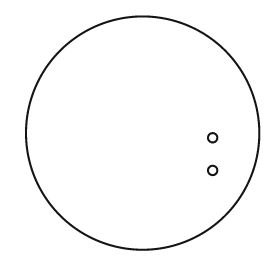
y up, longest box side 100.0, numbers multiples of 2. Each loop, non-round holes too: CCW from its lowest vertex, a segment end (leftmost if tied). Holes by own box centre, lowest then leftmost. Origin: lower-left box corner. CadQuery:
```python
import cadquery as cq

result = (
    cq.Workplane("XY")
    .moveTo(50.0, 50.0)
    .circle(50.0)
    .moveTo(80.0, 34.0)
    .circle(2.0)
    .moveTo(80.0, 48.0)
    .circle(2.0)
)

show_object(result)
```